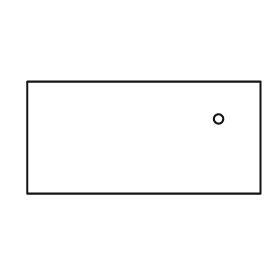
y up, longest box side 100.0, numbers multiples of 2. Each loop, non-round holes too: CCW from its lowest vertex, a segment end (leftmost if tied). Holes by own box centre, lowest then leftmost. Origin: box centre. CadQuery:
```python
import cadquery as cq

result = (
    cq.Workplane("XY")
    .moveTo(-50.0, -24.0)
    .lineTo(50.0, -24.0)
    .lineTo(50.0, 24.0)
    .lineTo(-50.0, 24.0)
    .close()
    .moveTo(32.0, 8.0)
    .circle(2.0)
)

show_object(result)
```